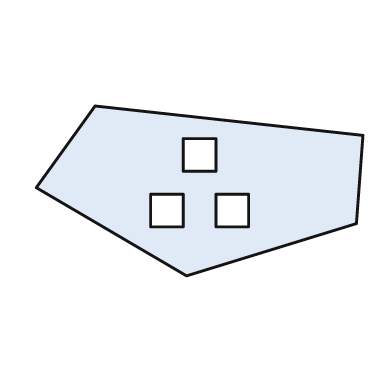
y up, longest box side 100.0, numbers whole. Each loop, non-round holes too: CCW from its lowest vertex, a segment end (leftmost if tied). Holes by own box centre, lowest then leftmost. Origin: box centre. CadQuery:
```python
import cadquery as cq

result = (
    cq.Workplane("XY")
    .moveTo(-4.0, -26.0)
    .lineTo(48.0, -10.0)
    .lineTo(50.0, 17.0)
    .lineTo(-32.0, 26.0)
    .lineTo(-50.0, 1.0)
    .close()
    .moveTo(-15.0, -11.0)
    .lineTo(-5.0, -11.0)
    .lineTo(-5.0, -1.0)
    .lineTo(-15.0, -1.0)
    .close()
    .moveTo(5.0, -11.0)
    .lineTo(15.0, -11.0)
    .lineTo(15.0, -1.0)
    .lineTo(5.0, -1.0)
    .close()
    .moveTo(-5.0, 6.0)
    .lineTo(5.0, 6.0)
    .lineTo(5.0, 16.0)
    .lineTo(-5.0, 16.0)
    .close()
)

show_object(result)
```